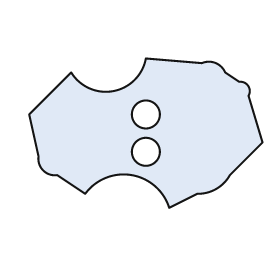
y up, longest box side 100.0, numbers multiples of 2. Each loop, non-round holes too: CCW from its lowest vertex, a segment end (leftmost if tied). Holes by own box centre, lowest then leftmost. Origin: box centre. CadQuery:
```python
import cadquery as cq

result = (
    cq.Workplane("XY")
    .moveTo(10.0, -32.0)
    .lineTo(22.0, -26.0)
    .threePointArc((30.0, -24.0), (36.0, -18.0))
    .lineTo(50.0, -4.0)
    .lineTo(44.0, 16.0)
    .threePointArc((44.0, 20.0), (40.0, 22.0))
    .lineTo(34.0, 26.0)
    .threePointArc((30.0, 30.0), (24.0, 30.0))
    .lineTo(0.0, 32.0)
    .threePointArc((-14.0, 18.0), (-32.0, 26.0))
    .lineTo(-50.0, 8.0)
    .lineTo(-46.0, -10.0)
    .threePointArc((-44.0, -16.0), (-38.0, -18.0))
    .lineTo(-26.0, -26.0)
    .threePointArc((-6.0, -18.0), (10.0, -32.0))
    .close()
    .moveTo(0.0, -8.0)
    .circle(6.0)
    .moveTo(0.0, 8.0)
    .circle(6.0)
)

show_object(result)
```